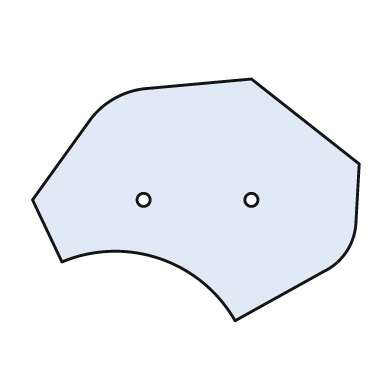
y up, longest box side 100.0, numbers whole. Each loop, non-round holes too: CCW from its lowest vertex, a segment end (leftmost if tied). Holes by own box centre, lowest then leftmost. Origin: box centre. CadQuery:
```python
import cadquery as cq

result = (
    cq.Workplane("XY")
    .moveTo(12.0, -37.0)
    .lineTo(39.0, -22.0)
    .threePointArc((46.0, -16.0), (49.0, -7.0))
    .lineTo(50.0, 11.0)
    .lineTo(17.0, 37.0)
    .lineTo(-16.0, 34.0)
    .threePointArc((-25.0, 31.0), (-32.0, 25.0))
    .lineTo(-50.0, 0.0)
    .lineTo(-41.0, -19.0)
    .threePointArc((-11.0, -18.0), (12.0, -37.0))
    .close()
    .moveTo(-16.0, 0.0)
    .circle(2.0)
    .moveTo(17.0, 0.0)
    .circle(2.0)
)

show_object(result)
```